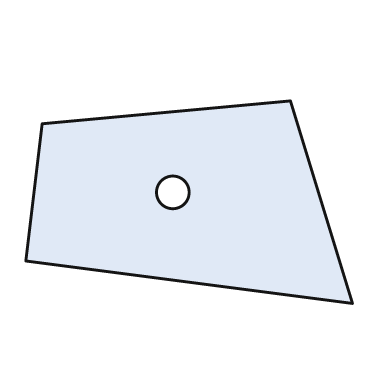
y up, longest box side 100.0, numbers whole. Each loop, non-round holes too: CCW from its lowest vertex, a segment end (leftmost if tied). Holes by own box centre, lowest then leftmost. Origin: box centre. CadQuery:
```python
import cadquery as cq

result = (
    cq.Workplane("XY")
    .moveTo(50.0, -31.0)
    .lineTo(31.0, 31.0)
    .lineTo(-45.0, 24.0)
    .lineTo(-50.0, -18.0)
    .close()
    .moveTo(-5.0, 3.0)
    .circle(5.0)
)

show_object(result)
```